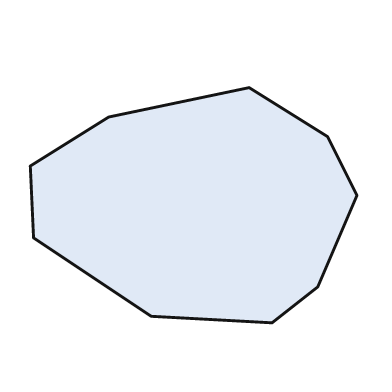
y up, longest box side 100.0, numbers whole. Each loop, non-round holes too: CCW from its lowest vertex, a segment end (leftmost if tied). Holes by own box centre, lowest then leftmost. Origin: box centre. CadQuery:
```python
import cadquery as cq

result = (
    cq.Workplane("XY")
    .moveTo(24.0, -36.0)
    .lineTo(38.0, -25.0)
    .lineTo(50.0, 3.0)
    .lineTo(41.0, 21.0)
    .lineTo(17.0, 36.0)
    .lineTo(-26.0, 27.0)
    .lineTo(-50.0, 12.0)
    .lineTo(-49.0, -10.0)
    .lineTo(-13.0, -34.0)
    .close()
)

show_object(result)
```